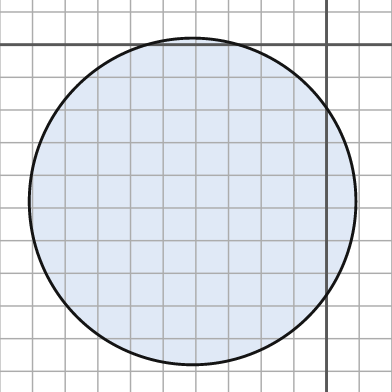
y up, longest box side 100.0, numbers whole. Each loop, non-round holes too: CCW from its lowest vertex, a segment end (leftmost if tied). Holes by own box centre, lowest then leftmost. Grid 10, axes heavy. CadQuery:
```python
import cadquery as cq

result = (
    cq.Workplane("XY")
    .moveTo(-41.0, -48.0)
    .circle(50.0)
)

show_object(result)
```